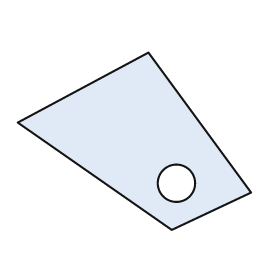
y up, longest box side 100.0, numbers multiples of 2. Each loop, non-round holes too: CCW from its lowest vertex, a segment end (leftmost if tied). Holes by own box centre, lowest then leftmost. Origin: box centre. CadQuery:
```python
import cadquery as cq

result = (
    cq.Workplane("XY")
    .moveTo(16.0, -38.0)
    .lineTo(50.0, -22.0)
    .lineTo(6.0, 38.0)
    .lineTo(-50.0, 8.0)
    .close()
    .moveTo(18.0, -18.0)
    .circle(8.0)
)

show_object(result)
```